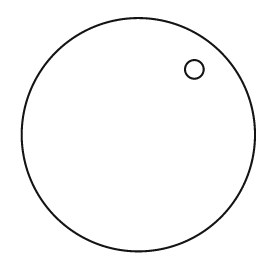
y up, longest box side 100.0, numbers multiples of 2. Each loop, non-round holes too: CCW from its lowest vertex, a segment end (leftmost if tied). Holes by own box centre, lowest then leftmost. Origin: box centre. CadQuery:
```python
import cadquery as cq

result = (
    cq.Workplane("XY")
    .moveTo(0.0, 0.0)
    .circle(50.0)
    .moveTo(24.0, 28.0)
    .circle(4.0)
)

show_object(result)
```